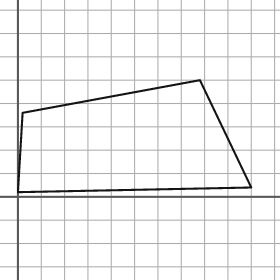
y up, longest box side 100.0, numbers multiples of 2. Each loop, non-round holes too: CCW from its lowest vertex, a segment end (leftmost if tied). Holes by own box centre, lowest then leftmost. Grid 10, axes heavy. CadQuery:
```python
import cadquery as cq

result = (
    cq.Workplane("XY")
    .moveTo(0.0, 2.0)
    .lineTo(100.0, 4.0)
    .lineTo(78.0, 50.0)
    .lineTo(2.0, 36.0)
    .close()
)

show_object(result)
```